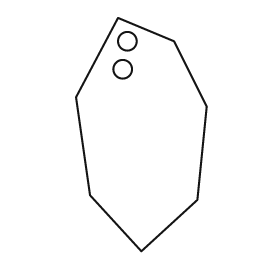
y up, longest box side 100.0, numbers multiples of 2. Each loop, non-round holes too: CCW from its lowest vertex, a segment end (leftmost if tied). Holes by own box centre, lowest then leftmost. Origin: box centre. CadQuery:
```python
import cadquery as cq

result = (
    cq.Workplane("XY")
    .moveTo(0.0, -50.0)
    .lineTo(24.0, -28.0)
    .lineTo(28.0, 12.0)
    .lineTo(14.0, 40.0)
    .lineTo(-10.0, 50.0)
    .lineTo(-28.0, 16.0)
    .lineTo(-22.0, -26.0)
    .close()
    .moveTo(-8.0, 28.0)
    .circle(4.0)
    .moveTo(-6.0, 40.0)
    .circle(4.0)
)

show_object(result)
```